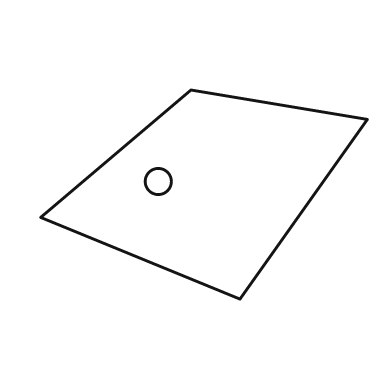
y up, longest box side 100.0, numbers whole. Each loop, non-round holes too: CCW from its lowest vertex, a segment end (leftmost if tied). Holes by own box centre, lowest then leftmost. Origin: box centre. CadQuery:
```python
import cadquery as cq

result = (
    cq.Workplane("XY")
    .moveTo(11.0, -32.0)
    .lineTo(50.0, 23.0)
    .lineTo(-4.0, 32.0)
    .lineTo(-50.0, -7.0)
    .close()
    .moveTo(-14.0, 4.0)
    .circle(4.0)
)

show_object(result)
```